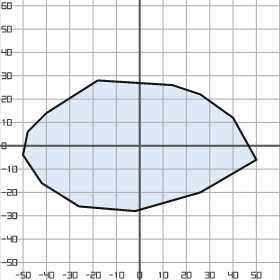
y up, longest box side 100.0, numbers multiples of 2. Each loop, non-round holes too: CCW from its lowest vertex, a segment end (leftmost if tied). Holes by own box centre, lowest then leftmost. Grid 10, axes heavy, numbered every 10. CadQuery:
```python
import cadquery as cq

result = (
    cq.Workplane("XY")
    .moveTo(-2.0, -28.0)
    .lineTo(26.0, -20.0)
    .lineTo(50.0, -6.0)
    .lineTo(40.0, 12.0)
    .lineTo(26.0, 22.0)
    .lineTo(14.0, 26.0)
    .lineTo(-18.0, 28.0)
    .lineTo(-40.0, 14.0)
    .lineTo(-48.0, 6.0)
    .lineTo(-50.0, -4.0)
    .lineTo(-42.0, -16.0)
    .lineTo(-26.0, -26.0)
    .close()
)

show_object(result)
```